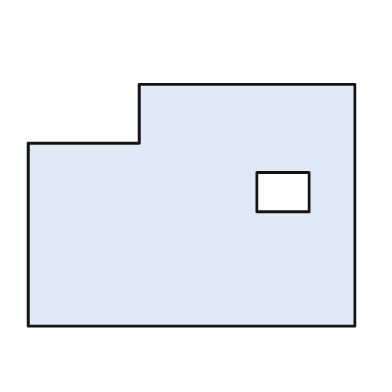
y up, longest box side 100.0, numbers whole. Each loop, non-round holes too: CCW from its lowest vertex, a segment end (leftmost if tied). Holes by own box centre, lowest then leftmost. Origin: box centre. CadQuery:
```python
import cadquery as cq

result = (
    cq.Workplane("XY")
    .moveTo(-50.0, -37.0)
    .lineTo(50.0, -37.0)
    .lineTo(50.0, 37.0)
    .lineTo(-16.0, 37.0)
    .lineTo(-16.0, 19.0)
    .lineTo(-50.0, 19.0)
    .close()
    .moveTo(20.0, -2.0)
    .lineTo(36.0, -2.0)
    .lineTo(36.0, 10.0)
    .lineTo(20.0, 10.0)
    .close()
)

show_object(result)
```